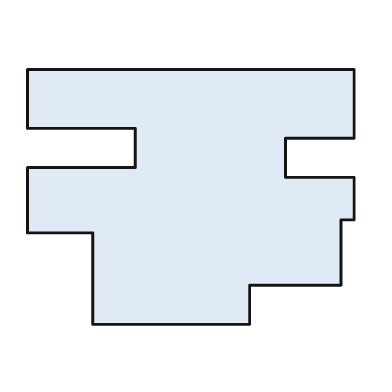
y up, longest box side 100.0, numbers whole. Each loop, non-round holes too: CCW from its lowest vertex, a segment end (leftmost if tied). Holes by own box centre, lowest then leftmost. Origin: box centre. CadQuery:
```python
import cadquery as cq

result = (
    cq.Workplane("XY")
    .moveTo(-30.0, -39.0)
    .lineTo(18.0, -39.0)
    .lineTo(18.0, -27.0)
    .lineTo(46.0, -27.0)
    .lineTo(46.0, -7.0)
    .lineTo(50.0, -7.0)
    .lineTo(50.0, 6.0)
    .lineTo(29.0, 6.0)
    .lineTo(29.0, 18.0)
    .lineTo(50.0, 18.0)
    .lineTo(50.0, 39.0)
    .lineTo(-50.0, 39.0)
    .lineTo(-50.0, 21.0)
    .lineTo(-17.0, 21.0)
    .lineTo(-17.0, 9.0)
    .lineTo(-50.0, 9.0)
    .lineTo(-50.0, -11.0)
    .lineTo(-30.0, -11.0)
    .close()
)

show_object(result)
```